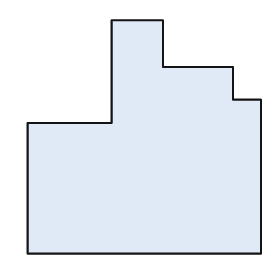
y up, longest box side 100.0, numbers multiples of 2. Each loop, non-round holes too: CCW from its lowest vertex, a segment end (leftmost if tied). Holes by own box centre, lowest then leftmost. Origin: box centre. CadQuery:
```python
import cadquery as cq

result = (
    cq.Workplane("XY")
    .moveTo(-50.0, -50.0)
    .lineTo(50.0, -50.0)
    .lineTo(50.0, 16.0)
    .lineTo(38.0, 16.0)
    .lineTo(38.0, 30.0)
    .lineTo(8.0, 30.0)
    .lineTo(8.0, 50.0)
    .lineTo(-14.0, 50.0)
    .lineTo(-14.0, 6.0)
    .lineTo(-50.0, 6.0)
    .close()
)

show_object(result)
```